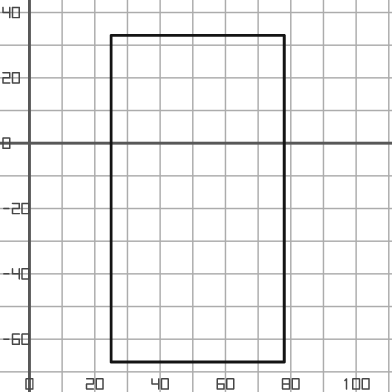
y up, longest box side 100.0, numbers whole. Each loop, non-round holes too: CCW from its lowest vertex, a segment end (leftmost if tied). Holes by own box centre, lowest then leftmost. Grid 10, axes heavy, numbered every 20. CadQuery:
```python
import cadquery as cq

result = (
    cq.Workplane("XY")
    .moveTo(25.0, -67.0)
    .lineTo(78.0, -67.0)
    .lineTo(78.0, 33.0)
    .lineTo(25.0, 33.0)
    .close()
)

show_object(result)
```